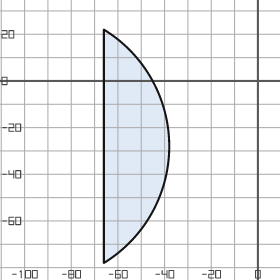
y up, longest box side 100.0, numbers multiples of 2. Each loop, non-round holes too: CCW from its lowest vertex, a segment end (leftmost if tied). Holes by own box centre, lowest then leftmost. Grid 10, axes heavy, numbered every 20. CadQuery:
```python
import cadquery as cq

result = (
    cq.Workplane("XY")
    .moveTo(-66.0, -78.0)
    .threePointArc((-38.0, -28.0), (-66.0, 22.0))
    .close()
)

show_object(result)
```